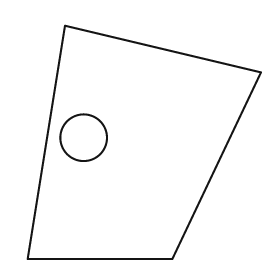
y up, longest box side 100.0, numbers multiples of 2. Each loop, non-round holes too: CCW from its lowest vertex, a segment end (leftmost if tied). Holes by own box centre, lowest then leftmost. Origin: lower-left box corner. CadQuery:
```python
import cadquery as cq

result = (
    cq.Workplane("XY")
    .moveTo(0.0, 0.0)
    .lineTo(62.0, 0.0)
    .lineTo(100.0, 80.0)
    .lineTo(16.0, 100.0)
    .close()
    .moveTo(24.0, 52.0)
    .circle(10.0)
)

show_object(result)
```